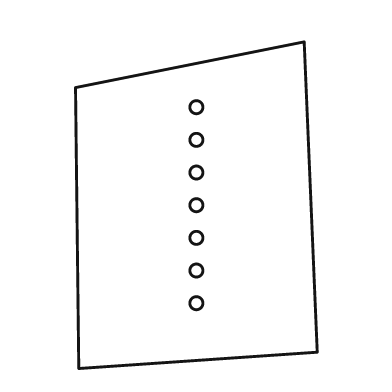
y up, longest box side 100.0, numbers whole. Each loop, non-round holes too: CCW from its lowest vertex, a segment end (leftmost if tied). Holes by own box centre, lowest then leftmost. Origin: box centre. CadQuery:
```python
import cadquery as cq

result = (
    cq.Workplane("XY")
    .moveTo(-36.0, -50.0)
    .lineTo(37.0, -45.0)
    .lineTo(33.0, 50.0)
    .lineTo(-37.0, 36.0)
    .close()
    .moveTo(0.0, -30.0)
    .circle(2.0)
    .moveTo(0.0, -20.0)
    .circle(2.0)
    .moveTo(0.0, -10.0)
    .circle(2.0)
    .moveTo(0.0, 0.0)
    .circle(2.0)
    .moveTo(0.0, 10.0)
    .circle(2.0)
    .moveTo(0.0, 20.0)
    .circle(2.0)
    .moveTo(0.0, 30.0)
    .circle(2.0)
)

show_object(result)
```